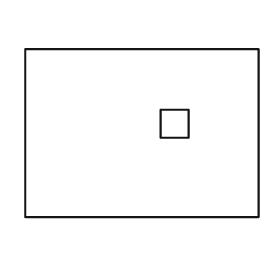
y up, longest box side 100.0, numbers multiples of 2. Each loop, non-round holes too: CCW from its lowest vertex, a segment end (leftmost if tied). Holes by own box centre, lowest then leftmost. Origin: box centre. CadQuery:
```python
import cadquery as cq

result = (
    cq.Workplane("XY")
    .moveTo(-50.0, -36.0)
    .lineTo(50.0, -36.0)
    .lineTo(50.0, 36.0)
    .lineTo(-50.0, 36.0)
    .close()
    .moveTo(8.0, -2.0)
    .lineTo(20.0, -2.0)
    .lineTo(20.0, 10.0)
    .lineTo(8.0, 10.0)
    .close()
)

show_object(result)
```